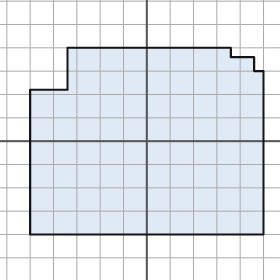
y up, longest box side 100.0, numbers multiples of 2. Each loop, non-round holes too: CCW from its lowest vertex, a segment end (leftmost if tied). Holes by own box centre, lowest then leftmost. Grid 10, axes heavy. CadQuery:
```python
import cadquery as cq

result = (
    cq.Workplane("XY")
    .moveTo(-50.0, -40.0)
    .lineTo(50.0, -40.0)
    .lineTo(50.0, 30.0)
    .lineTo(46.0, 30.0)
    .lineTo(46.0, 36.0)
    .lineTo(36.0, 36.0)
    .lineTo(36.0, 40.0)
    .lineTo(-34.0, 40.0)
    .lineTo(-34.0, 22.0)
    .lineTo(-50.0, 22.0)
    .close()
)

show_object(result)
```